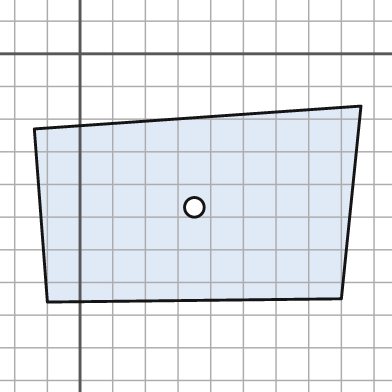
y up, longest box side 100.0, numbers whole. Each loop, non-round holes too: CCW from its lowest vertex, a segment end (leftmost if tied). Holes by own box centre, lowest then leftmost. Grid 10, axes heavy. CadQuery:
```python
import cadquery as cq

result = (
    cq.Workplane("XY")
    .moveTo(-10.0, -76.0)
    .lineTo(80.0, -75.0)
    .lineTo(86.0, -16.0)
    .lineTo(-14.0, -23.0)
    .close()
    .moveTo(35.0, -47.0)
    .circle(3.0)
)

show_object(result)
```